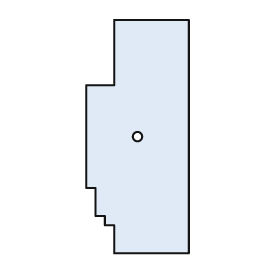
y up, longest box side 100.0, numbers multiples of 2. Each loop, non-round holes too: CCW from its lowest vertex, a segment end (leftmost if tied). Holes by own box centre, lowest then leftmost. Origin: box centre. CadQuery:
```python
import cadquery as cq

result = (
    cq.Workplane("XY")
    .moveTo(-10.0, -50.0)
    .lineTo(22.0, -50.0)
    .lineTo(22.0, 50.0)
    .lineTo(-10.0, 50.0)
    .lineTo(-10.0, 22.0)
    .lineTo(-22.0, 22.0)
    .lineTo(-22.0, -22.0)
    .lineTo(-18.0, -22.0)
    .lineTo(-18.0, -34.0)
    .lineTo(-14.0, -34.0)
    .lineTo(-14.0, -38.0)
    .lineTo(-10.0, -38.0)
    .close()
    .moveTo(0.0, 0.0)
    .circle(2.0)
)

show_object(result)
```